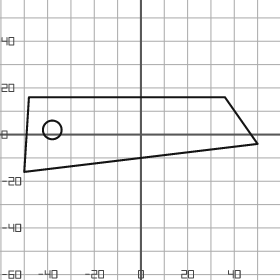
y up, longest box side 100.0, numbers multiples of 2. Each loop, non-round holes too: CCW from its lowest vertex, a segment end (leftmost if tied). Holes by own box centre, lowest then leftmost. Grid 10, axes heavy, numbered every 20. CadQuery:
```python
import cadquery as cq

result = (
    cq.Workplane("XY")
    .moveTo(-50.0, -16.0)
    .lineTo(50.0, -4.0)
    .lineTo(36.0, 16.0)
    .lineTo(-48.0, 16.0)
    .close()
    .moveTo(-38.0, 2.0)
    .circle(4.0)
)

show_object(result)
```